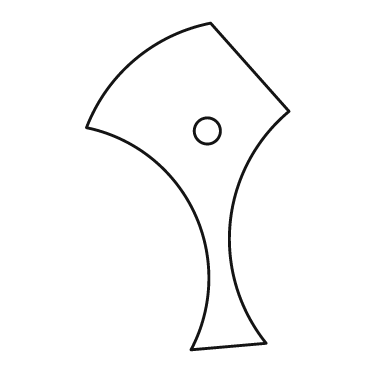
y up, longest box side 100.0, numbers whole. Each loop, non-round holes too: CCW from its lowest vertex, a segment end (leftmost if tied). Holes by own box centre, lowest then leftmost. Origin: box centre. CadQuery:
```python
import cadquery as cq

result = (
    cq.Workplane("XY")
    .moveTo(1.0, -50.0)
    .lineTo(24.0, -48.0)
    .threePointArc((13.0, -11.0), (31.0, 23.0))
    .lineTo(7.0, 50.0)
    .threePointArc((-16.0, 39.0), (-31.0, 18.0))
    .threePointArc((2.0, -8.0), (1.0, -50.0))
    .close()
    .moveTo(6.0, 17.0)
    .circle(4.0)
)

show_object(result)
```